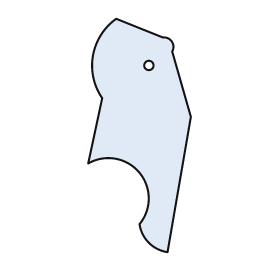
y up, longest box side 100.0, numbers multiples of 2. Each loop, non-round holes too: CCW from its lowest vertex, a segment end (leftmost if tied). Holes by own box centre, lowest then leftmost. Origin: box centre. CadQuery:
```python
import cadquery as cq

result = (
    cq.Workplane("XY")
    .moveTo(12.0, -50.0)
    .lineTo(22.0, 8.0)
    .lineTo(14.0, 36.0)
    .threePointArc((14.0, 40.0), (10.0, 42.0))
    .lineTo(-10.0, 50.0)
    .threePointArc((-20.0, 34.0), (-16.0, 16.0))
    .lineTo(-22.0, -12.0)
    .threePointArc((0.0, -16.0), (0.0, -38.0))
    .threePointArc((4.0, -46.0), (12.0, -50.0))
    .close()
    .moveTo(4.0, 30.0)
    .circle(2.0)
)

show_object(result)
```